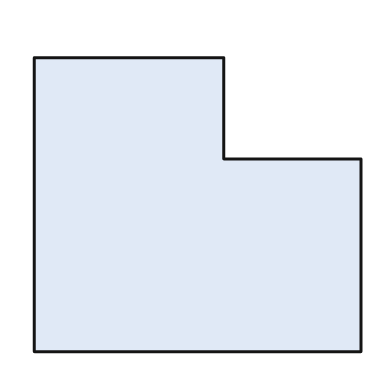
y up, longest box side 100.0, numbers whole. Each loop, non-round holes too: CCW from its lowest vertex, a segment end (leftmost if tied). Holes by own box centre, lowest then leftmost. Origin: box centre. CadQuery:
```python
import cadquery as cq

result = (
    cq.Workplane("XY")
    .moveTo(-50.0, -45.0)
    .lineTo(50.0, -45.0)
    .lineTo(50.0, 14.0)
    .lineTo(8.0, 14.0)
    .lineTo(8.0, 45.0)
    .lineTo(-50.0, 45.0)
    .close()
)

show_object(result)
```